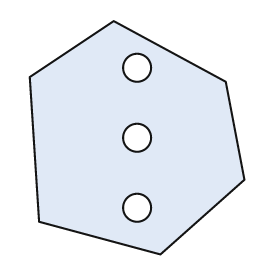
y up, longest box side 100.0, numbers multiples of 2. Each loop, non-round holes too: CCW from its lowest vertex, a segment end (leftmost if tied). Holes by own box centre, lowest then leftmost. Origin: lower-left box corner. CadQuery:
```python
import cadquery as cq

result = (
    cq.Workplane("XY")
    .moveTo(56.0, 0.0)
    .lineTo(92.0, 32.0)
    .lineTo(84.0, 74.0)
    .lineTo(36.0, 100.0)
    .lineTo(0.0, 76.0)
    .lineTo(4.0, 14.0)
    .close()
    .moveTo(46.0, 20.0)
    .circle(6.0)
    .moveTo(46.0, 50.0)
    .circle(6.0)
    .moveTo(46.0, 80.0)
    .circle(6.0)
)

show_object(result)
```